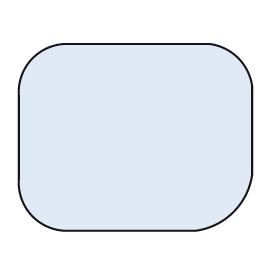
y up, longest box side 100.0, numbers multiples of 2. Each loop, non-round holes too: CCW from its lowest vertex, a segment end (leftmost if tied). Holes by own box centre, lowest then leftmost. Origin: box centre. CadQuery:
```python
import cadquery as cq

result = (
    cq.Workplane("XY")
    .moveTo(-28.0, -40.0)
    .lineTo(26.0, -40.0)
    .threePointArc((42.0, -32.0), (50.0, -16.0))
    .lineTo(50.0, 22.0)
    .threePointArc((44.0, 34.0), (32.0, 40.0))
    .lineTo(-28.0, 40.0)
    .threePointArc((-44.0, 34.0), (-50.0, 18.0))
    .lineTo(-50.0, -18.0)
    .threePointArc((-44.0, -34.0), (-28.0, -40.0))
    .close()
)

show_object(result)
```